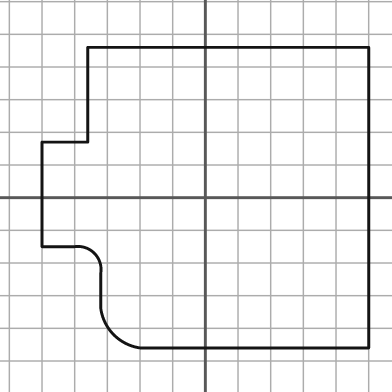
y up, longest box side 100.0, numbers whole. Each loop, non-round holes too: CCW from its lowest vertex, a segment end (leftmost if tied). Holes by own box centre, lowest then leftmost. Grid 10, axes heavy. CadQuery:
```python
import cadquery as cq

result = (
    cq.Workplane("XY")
    .moveTo(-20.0, -46.0)
    .lineTo(50.0, -46.0)
    .lineTo(50.0, 46.0)
    .lineTo(-36.0, 46.0)
    .lineTo(-36.0, 17.0)
    .lineTo(-50.0, 17.0)
    .lineTo(-50.0, -15.0)
    .lineTo(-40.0, -15.0)
    .threePointArc((-34.0, -17.0), (-32.0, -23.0))
    .lineTo(-32.0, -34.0)
    .threePointArc((-28.0, -42.0), (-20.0, -46.0))
    .close()
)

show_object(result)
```